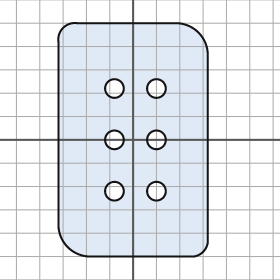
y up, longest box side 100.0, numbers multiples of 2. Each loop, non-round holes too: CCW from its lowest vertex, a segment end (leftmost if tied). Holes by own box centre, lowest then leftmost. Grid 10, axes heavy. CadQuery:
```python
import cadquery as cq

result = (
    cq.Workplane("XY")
    .moveTo(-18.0, -50.0)
    .lineTo(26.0, -50.0)
    .threePointArc((30.0, -48.0), (32.0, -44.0))
    .lineTo(32.0, 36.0)
    .threePointArc((28.0, 46.0), (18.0, 50.0))
    .lineTo(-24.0, 50.0)
    .threePointArc((-30.0, 48.0), (-32.0, 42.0))
    .lineTo(-32.0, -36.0)
    .threePointArc((-28.0, -46.0), (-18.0, -50.0))
    .close()
    .moveTo(-8.0, -22.0)
    .circle(4.0)
    .moveTo(10.0, -22.0)
    .circle(4.0)
    .moveTo(-8.0, 0.0)
    .circle(4.0)
    .moveTo(10.0, 0.0)
    .circle(4.0)
    .moveTo(-8.0, 22.0)
    .circle(4.0)
    .moveTo(10.0, 22.0)
    .circle(4.0)
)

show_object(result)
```